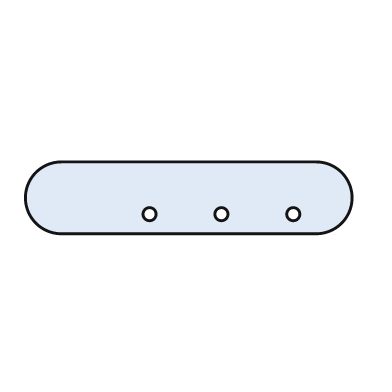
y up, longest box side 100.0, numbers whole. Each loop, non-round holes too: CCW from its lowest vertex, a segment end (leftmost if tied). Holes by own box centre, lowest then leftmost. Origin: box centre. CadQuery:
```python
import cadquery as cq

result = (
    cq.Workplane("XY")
    .moveTo(-39.0, -11.0)
    .lineTo(39.0, -11.0)
    .threePointArc((50.0, 0.0), (39.0, 11.0))
    .lineTo(-39.0, 11.0)
    .threePointArc((-50.0, 0.0), (-39.0, -11.0))
    .close()
    .moveTo(-12.0, -5.0)
    .circle(2.0)
    .moveTo(10.0, -5.0)
    .circle(2.0)
    .moveTo(32.0, -5.0)
    .circle(2.0)
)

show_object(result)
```